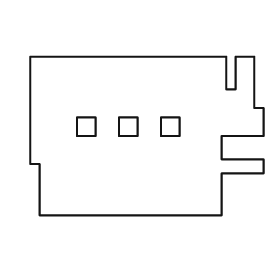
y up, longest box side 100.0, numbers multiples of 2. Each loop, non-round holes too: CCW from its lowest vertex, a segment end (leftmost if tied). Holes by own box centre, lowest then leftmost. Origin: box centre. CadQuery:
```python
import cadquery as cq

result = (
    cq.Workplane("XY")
    .moveTo(-46.0, -34.0)
    .lineTo(32.0, -34.0)
    .lineTo(32.0, -16.0)
    .lineTo(50.0, -16.0)
    .lineTo(50.0, -10.0)
    .lineTo(32.0, -10.0)
    .lineTo(32.0, 0.0)
    .lineTo(50.0, 0.0)
    .lineTo(50.0, 12.0)
    .lineTo(46.0, 12.0)
    .lineTo(46.0, 34.0)
    .lineTo(38.0, 34.0)
    .lineTo(38.0, 20.0)
    .lineTo(34.0, 20.0)
    .lineTo(34.0, 34.0)
    .lineTo(-50.0, 34.0)
    .lineTo(-50.0, -12.0)
    .lineTo(-46.0, -12.0)
    .close()
    .moveTo(-30.0, 0.0)
    .lineTo(-22.0, 0.0)
    .lineTo(-22.0, 8.0)
    .lineTo(-30.0, 8.0)
    .close()
    .moveTo(-12.0, 0.0)
    .lineTo(-4.0, 0.0)
    .lineTo(-4.0, 8.0)
    .lineTo(-12.0, 8.0)
    .close()
    .moveTo(6.0, 0.0)
    .lineTo(14.0, 0.0)
    .lineTo(14.0, 8.0)
    .lineTo(6.0, 8.0)
    .close()
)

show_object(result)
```